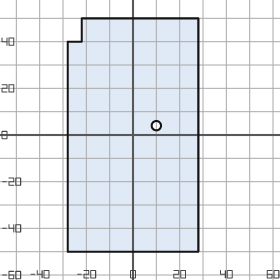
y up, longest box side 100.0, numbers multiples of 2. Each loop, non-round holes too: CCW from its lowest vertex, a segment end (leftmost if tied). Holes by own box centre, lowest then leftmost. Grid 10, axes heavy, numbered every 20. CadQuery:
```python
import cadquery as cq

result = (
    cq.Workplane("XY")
    .moveTo(-28.0, -50.0)
    .lineTo(28.0, -50.0)
    .lineTo(28.0, 50.0)
    .lineTo(-22.0, 50.0)
    .lineTo(-22.0, 40.0)
    .lineTo(-28.0, 40.0)
    .close()
    .moveTo(10.0, 4.0)
    .circle(2.0)
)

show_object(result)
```